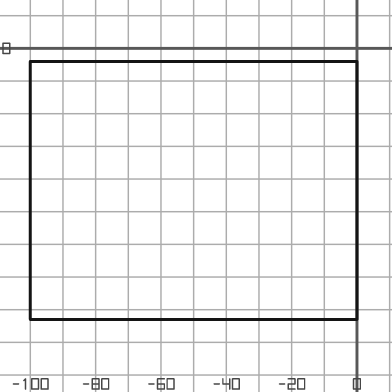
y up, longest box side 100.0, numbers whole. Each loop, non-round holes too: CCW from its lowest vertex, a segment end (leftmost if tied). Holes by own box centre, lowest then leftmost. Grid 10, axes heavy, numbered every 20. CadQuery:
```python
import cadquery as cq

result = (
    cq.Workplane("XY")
    .moveTo(-100.0, -83.0)
    .lineTo(0.0, -83.0)
    .lineTo(0.0, -4.0)
    .lineTo(-100.0, -4.0)
    .close()
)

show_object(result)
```